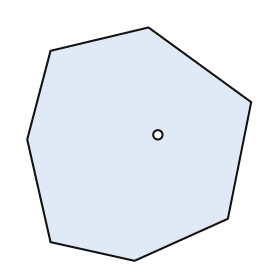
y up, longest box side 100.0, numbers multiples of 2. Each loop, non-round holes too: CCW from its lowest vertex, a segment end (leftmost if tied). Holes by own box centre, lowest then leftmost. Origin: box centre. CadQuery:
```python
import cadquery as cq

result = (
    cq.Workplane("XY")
    .moveTo(-2.0, -50.0)
    .lineTo(38.0, -32.0)
    .lineTo(48.0, 18.0)
    .lineTo(4.0, 50.0)
    .lineTo(-38.0, 40.0)
    .lineTo(-48.0, 2.0)
    .lineTo(-38.0, -42.0)
    .close()
    .moveTo(8.0, 4.0)
    .circle(2.0)
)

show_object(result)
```